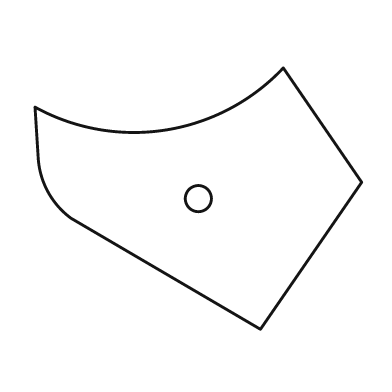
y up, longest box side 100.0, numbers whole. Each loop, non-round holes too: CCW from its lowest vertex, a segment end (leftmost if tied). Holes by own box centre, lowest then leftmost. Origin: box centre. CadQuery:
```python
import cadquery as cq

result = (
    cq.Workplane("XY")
    .moveTo(19.0, -40.0)
    .lineTo(50.0, 5.0)
    .lineTo(26.0, 40.0)
    .threePointArc((-10.0, 21.0), (-50.0, 28.0))
    .lineTo(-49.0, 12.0)
    .threePointArc((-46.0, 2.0), (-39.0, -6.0))
    .close()
    .moveTo(0.0, 0.0)
    .circle(4.0)
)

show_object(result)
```